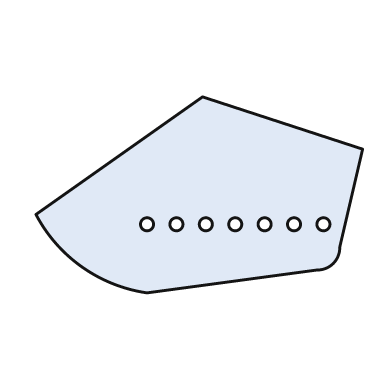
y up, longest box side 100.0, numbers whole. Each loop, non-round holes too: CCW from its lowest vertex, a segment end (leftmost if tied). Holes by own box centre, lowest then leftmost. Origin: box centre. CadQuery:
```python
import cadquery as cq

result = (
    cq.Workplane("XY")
    .moveTo(-16.0, -30.0)
    .lineTo(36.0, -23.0)
    .threePointArc((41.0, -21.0), (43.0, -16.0))
    .lineTo(50.0, 14.0)
    .lineTo(1.0, 30.0)
    .lineTo(-50.0, -6.0)
    .threePointArc((-36.0, -22.0), (-16.0, -30.0))
    .close()
    .moveTo(-16.0, -9.0)
    .circle(2.0)
    .moveTo(-7.0, -9.0)
    .circle(2.0)
    .moveTo(2.0, -9.0)
    .circle(2.0)
    .moveTo(11.0, -9.0)
    .circle(2.0)
    .moveTo(20.0, -9.0)
    .circle(2.0)
    .moveTo(29.0, -9.0)
    .circle(2.0)
    .moveTo(38.0, -9.0)
    .circle(2.0)
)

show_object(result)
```